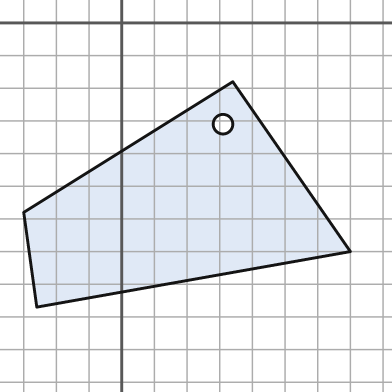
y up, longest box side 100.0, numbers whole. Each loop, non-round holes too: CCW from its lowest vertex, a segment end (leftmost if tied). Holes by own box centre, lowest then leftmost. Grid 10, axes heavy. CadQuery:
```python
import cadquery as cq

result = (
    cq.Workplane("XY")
    .moveTo(-26.0, -87.0)
    .lineTo(70.0, -70.0)
    .lineTo(34.0, -18.0)
    .lineTo(-30.0, -58.0)
    .close()
    .moveTo(31.0, -31.0)
    .circle(3.0)
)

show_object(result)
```